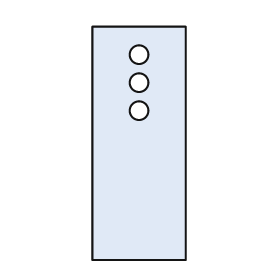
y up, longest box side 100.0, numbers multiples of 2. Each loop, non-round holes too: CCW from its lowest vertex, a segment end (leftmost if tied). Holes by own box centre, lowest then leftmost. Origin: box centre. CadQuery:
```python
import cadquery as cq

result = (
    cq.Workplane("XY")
    .moveTo(-20.0, -50.0)
    .lineTo(20.0, -50.0)
    .lineTo(20.0, 50.0)
    .lineTo(-20.0, 50.0)
    .close()
    .moveTo(0.0, 14.0)
    .circle(4.0)
    .moveTo(0.0, 26.0)
    .circle(4.0)
    .moveTo(0.0, 38.0)
    .circle(4.0)
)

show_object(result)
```